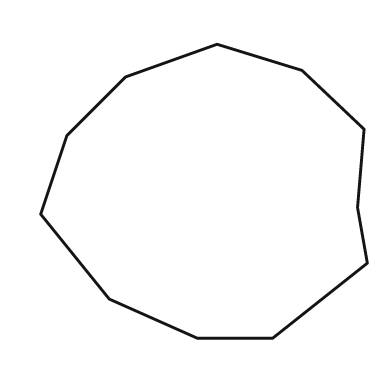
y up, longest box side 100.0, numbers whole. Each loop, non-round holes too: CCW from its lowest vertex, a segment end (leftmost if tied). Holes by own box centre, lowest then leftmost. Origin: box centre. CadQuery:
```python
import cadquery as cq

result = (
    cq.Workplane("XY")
    .moveTo(-2.0, -45.0)
    .lineTo(21.0, -45.0)
    .lineTo(50.0, -22.0)
    .lineTo(47.0, -5.0)
    .lineTo(49.0, 19.0)
    .lineTo(30.0, 37.0)
    .lineTo(4.0, 45.0)
    .lineTo(-24.0, 35.0)
    .lineTo(-42.0, 17.0)
    .lineTo(-50.0, -7.0)
    .lineTo(-29.0, -33.0)
    .close()
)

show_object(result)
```